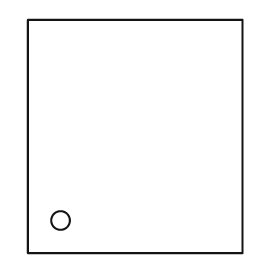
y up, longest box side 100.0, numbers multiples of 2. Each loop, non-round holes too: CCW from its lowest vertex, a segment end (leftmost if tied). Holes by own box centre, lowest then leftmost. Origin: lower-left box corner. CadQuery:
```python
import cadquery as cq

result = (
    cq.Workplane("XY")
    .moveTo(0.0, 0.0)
    .lineTo(92.0, 0.0)
    .lineTo(92.0, 100.0)
    .lineTo(0.0, 100.0)
    .close()
    .moveTo(14.0, 14.0)
    .circle(4.0)
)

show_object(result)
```